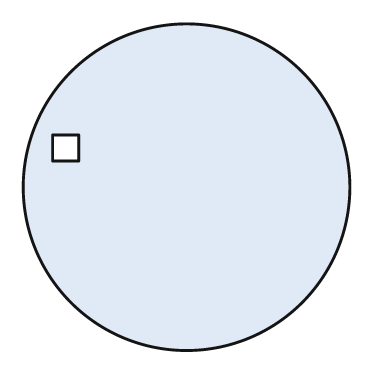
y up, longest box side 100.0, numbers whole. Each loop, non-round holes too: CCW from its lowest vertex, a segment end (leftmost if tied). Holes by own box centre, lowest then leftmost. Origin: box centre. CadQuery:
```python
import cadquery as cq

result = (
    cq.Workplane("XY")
    .moveTo(0.0, 0.0)
    .circle(50.0)
    .moveTo(-41.0, 8.0)
    .lineTo(-33.0, 8.0)
    .lineTo(-33.0, 16.0)
    .lineTo(-41.0, 16.0)
    .close()
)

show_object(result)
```